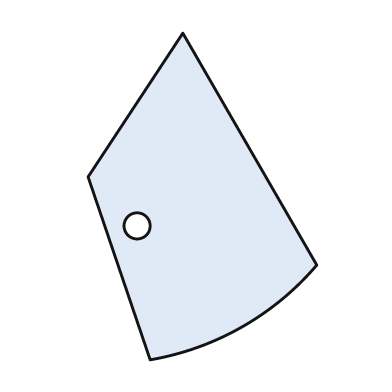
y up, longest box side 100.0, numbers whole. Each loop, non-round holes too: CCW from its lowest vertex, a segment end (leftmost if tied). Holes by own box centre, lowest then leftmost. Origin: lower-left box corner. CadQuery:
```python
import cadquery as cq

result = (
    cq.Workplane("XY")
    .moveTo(19.0, 0.0)
    .threePointArc((47.0, 10.0), (70.0, 29.0))
    .lineTo(29.0, 100.0)
    .lineTo(0.0, 56.0)
    .close()
    .moveTo(15.0, 41.0)
    .circle(4.0)
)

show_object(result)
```